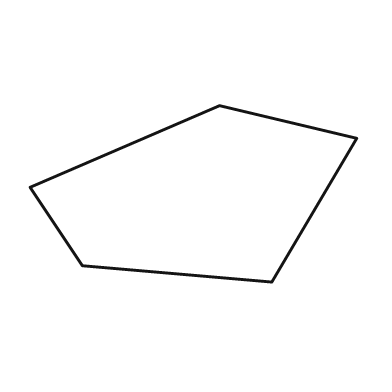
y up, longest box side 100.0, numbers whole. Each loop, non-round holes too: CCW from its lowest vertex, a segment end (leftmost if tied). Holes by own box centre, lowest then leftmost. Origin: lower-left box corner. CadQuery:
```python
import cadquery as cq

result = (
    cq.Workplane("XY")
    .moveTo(74.0, 0.0)
    .lineTo(100.0, 44.0)
    .lineTo(58.0, 54.0)
    .lineTo(0.0, 29.0)
    .lineTo(16.0, 5.0)
    .close()
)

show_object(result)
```